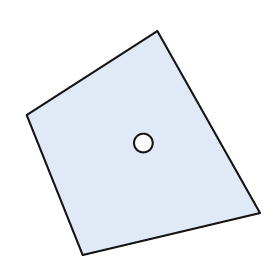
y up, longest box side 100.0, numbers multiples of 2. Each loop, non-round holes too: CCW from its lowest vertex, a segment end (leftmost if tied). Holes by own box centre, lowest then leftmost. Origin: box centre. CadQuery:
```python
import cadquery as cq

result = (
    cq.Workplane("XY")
    .moveTo(-26.0, -48.0)
    .lineTo(50.0, -30.0)
    .lineTo(6.0, 48.0)
    .lineTo(-50.0, 12.0)
    .close()
    .moveTo(0.0, 0.0)
    .circle(4.0)
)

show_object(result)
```